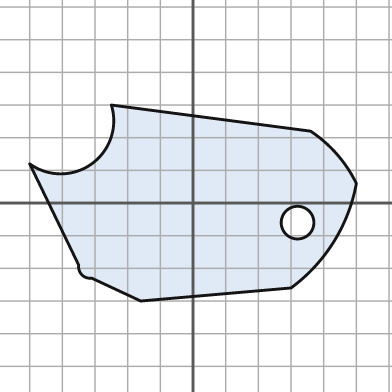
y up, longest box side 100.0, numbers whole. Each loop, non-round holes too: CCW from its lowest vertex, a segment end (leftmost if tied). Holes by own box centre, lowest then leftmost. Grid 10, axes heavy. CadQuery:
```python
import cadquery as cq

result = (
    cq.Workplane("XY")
    .moveTo(-16.0, -30.0)
    .lineTo(30.0, -26.0)
    .threePointArc((43.0, -12.0), (50.0, 6.0))
    .threePointArc((44.0, 15.0), (36.0, 22.0))
    .lineTo(-25.0, 30.0)
    .threePointArc((-31.0, 12.0), (-50.0, 12.0))
    .lineTo(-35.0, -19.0)
    .threePointArc((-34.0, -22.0), (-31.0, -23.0))
    .close()
    .moveTo(32.0, -6.0)
    .circle(5.0)
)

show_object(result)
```